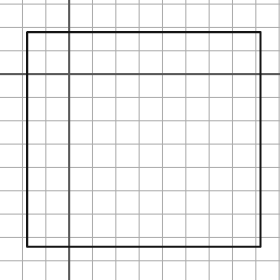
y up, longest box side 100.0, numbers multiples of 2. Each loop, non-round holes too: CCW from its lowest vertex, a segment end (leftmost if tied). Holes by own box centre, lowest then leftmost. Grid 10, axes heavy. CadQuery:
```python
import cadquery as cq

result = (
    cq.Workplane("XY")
    .moveTo(-18.0, -74.0)
    .lineTo(82.0, -74.0)
    .lineTo(82.0, 18.0)
    .lineTo(-18.0, 18.0)
    .close()
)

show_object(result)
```